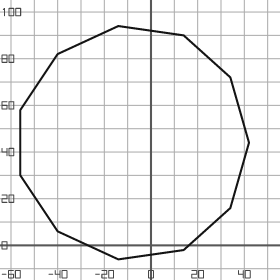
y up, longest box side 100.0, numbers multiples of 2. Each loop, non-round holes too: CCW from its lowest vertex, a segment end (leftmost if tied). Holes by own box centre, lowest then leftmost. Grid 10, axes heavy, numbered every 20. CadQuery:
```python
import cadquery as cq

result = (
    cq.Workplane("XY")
    .moveTo(-14.0, -6.0)
    .lineTo(14.0, -2.0)
    .lineTo(34.0, 16.0)
    .lineTo(42.0, 44.0)
    .lineTo(34.0, 72.0)
    .lineTo(14.0, 90.0)
    .lineTo(-14.0, 94.0)
    .lineTo(-40.0, 82.0)
    .lineTo(-56.0, 58.0)
    .lineTo(-56.0, 30.0)
    .lineTo(-40.0, 6.0)
    .close()
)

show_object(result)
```